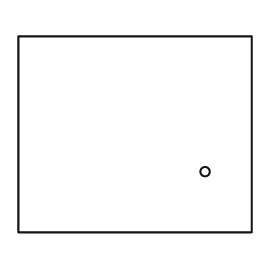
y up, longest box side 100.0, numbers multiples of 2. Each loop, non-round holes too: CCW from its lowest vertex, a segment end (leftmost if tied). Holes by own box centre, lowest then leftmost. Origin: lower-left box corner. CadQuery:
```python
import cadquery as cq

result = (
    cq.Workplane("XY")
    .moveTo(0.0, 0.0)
    .lineTo(100.0, 0.0)
    .lineTo(100.0, 84.0)
    .lineTo(0.0, 84.0)
    .close()
    .moveTo(80.0, 26.0)
    .circle(2.0)
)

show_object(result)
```